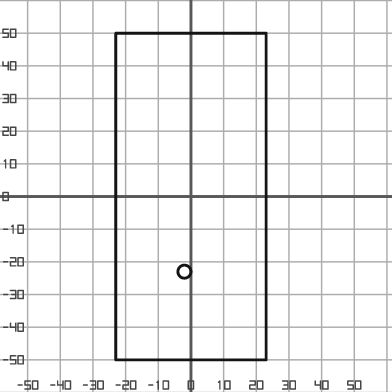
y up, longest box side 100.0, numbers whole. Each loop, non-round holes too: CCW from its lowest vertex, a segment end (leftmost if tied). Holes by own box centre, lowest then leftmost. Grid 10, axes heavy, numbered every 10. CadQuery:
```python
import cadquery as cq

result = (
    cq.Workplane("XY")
    .moveTo(-23.0, -50.0)
    .lineTo(23.0, -50.0)
    .lineTo(23.0, 50.0)
    .lineTo(-23.0, 50.0)
    .close()
    .moveTo(-2.0, -23.0)
    .circle(2.0)
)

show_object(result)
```